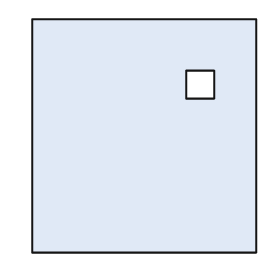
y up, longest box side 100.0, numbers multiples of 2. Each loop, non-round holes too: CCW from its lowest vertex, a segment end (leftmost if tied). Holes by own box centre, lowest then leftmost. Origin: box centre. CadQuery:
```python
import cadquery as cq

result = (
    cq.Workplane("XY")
    .moveTo(-48.0, -50.0)
    .lineTo(48.0, -50.0)
    .lineTo(48.0, 50.0)
    .lineTo(-48.0, 50.0)
    .close()
    .moveTo(18.0, 16.0)
    .lineTo(30.0, 16.0)
    .lineTo(30.0, 28.0)
    .lineTo(18.0, 28.0)
    .close()
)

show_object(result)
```